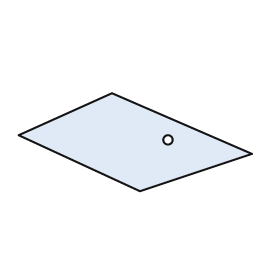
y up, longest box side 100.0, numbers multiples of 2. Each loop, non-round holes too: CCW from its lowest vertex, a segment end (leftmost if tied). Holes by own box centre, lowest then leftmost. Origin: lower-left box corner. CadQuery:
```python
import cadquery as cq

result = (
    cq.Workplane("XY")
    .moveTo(52.0, 0.0)
    .lineTo(100.0, 16.0)
    .lineTo(40.0, 42.0)
    .lineTo(0.0, 24.0)
    .close()
    .moveTo(64.0, 22.0)
    .circle(2.0)
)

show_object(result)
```